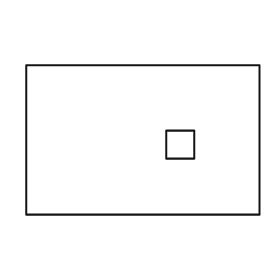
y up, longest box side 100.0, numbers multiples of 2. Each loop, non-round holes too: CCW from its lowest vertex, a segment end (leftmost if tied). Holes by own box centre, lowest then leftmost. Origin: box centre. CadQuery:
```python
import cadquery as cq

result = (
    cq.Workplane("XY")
    .moveTo(-50.0, -32.0)
    .lineTo(50.0, -32.0)
    .lineTo(50.0, 32.0)
    .lineTo(-50.0, 32.0)
    .close()
    .moveTo(10.0, -8.0)
    .lineTo(22.0, -8.0)
    .lineTo(22.0, 4.0)
    .lineTo(10.0, 4.0)
    .close()
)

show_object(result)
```